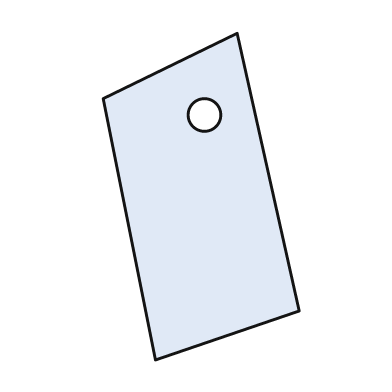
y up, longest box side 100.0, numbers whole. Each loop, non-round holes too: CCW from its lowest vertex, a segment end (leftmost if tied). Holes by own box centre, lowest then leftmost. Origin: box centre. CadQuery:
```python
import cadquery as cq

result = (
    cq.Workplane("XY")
    .moveTo(-14.0, -50.0)
    .lineTo(30.0, -35.0)
    .lineTo(11.0, 50.0)
    .lineTo(-30.0, 30.0)
    .close()
    .moveTo(1.0, 25.0)
    .circle(5.0)
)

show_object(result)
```